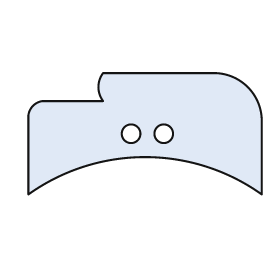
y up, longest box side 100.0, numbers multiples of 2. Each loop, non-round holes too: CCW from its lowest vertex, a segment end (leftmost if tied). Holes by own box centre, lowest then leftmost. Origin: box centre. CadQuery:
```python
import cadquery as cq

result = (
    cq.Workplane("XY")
    .moveTo(-50.0, -26.0)
    .threePointArc((0.0, -10.0), (50.0, -26.0))
    .lineTo(50.0, 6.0)
    .threePointArc((44.0, 20.0), (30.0, 26.0))
    .lineTo(-18.0, 26.0)
    .threePointArc((-20.0, 20.0), (-18.0, 14.0))
    .lineTo(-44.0, 14.0)
    .threePointArc((-48.0, 12.0), (-50.0, 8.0))
    .close()
    .moveTo(-6.0, 0.0)
    .circle(4.0)
    .moveTo(8.0, 0.0)
    .circle(4.0)
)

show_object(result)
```